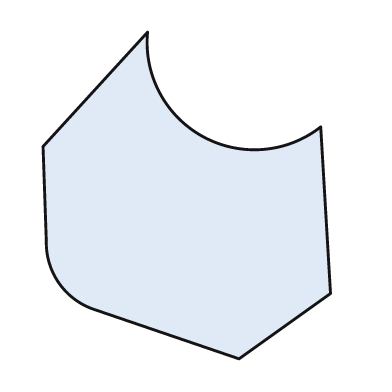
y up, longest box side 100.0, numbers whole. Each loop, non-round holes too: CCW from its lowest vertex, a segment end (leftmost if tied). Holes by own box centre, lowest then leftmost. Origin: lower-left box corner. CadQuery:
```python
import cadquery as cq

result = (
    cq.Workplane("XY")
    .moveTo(60.0, 0.0)
    .lineTo(88.0, 20.0)
    .lineTo(85.0, 71.0)
    .threePointArc((49.0, 68.0), (32.0, 100.0))
    .lineTo(0.0, 65.0)
    .lineTo(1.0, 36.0)
    .threePointArc((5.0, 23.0), (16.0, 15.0))
    .close()
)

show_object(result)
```